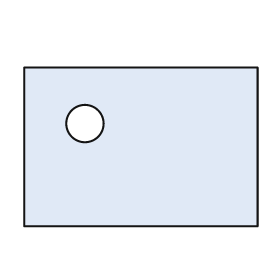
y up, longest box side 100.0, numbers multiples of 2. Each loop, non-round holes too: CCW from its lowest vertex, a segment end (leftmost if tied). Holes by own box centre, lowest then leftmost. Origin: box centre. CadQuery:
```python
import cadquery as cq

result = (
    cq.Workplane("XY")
    .moveTo(-50.0, -34.0)
    .lineTo(50.0, -34.0)
    .lineTo(50.0, 34.0)
    .lineTo(-50.0, 34.0)
    .close()
    .moveTo(-24.0, 10.0)
    .circle(8.0)
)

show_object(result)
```